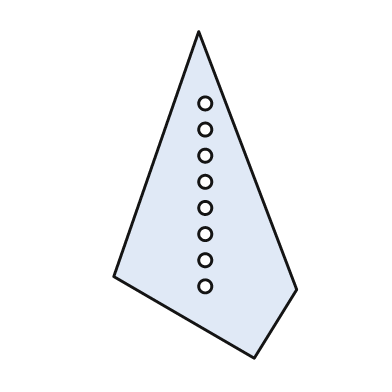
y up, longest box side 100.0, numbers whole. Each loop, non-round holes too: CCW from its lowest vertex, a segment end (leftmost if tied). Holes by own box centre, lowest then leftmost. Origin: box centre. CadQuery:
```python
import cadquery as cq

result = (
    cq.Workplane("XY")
    .moveTo(15.0, -50.0)
    .lineTo(28.0, -29.0)
    .lineTo(-2.0, 50.0)
    .lineTo(-28.0, -25.0)
    .close()
    .moveTo(0.0, -28.0)
    .circle(2.0)
    .moveTo(0.0, -20.0)
    .circle(2.0)
    .moveTo(0.0, -12.0)
    .circle(2.0)
    .moveTo(0.0, -4.0)
    .circle(2.0)
    .moveTo(0.0, 4.0)
    .circle(2.0)
    .moveTo(0.0, 12.0)
    .circle(2.0)
    .moveTo(0.0, 20.0)
    .circle(2.0)
    .moveTo(0.0, 28.0)
    .circle(2.0)
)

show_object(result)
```